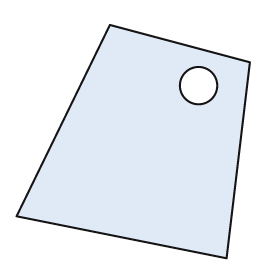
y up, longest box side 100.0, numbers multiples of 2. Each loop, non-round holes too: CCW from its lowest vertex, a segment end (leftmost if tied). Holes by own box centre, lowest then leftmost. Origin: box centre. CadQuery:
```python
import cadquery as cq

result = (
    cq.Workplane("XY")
    .moveTo(40.0, -50.0)
    .lineTo(50.0, 34.0)
    .lineTo(-10.0, 50.0)
    .lineTo(-50.0, -32.0)
    .close()
    .moveTo(28.0, 24.0)
    .circle(8.0)
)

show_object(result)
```